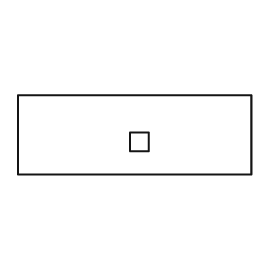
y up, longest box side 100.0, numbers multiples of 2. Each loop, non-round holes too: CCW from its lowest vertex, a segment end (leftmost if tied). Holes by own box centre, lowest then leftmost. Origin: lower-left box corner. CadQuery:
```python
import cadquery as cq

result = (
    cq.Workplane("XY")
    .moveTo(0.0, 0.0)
    .lineTo(100.0, 0.0)
    .lineTo(100.0, 34.0)
    .lineTo(0.0, 34.0)
    .close()
    .moveTo(48.0, 10.0)
    .lineTo(56.0, 10.0)
    .lineTo(56.0, 18.0)
    .lineTo(48.0, 18.0)
    .close()
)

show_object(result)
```